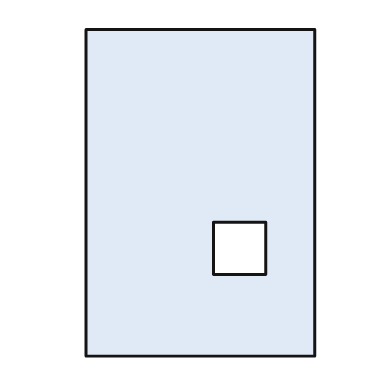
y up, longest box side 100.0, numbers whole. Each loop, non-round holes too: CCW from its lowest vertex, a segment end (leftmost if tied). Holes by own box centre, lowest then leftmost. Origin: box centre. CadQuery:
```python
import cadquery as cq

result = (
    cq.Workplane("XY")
    .moveTo(-35.0, -50.0)
    .lineTo(35.0, -50.0)
    .lineTo(35.0, 50.0)
    .lineTo(-35.0, 50.0)
    .close()
    .moveTo(4.0, -25.0)
    .lineTo(20.0, -25.0)
    .lineTo(20.0, -9.0)
    .lineTo(4.0, -9.0)
    .close()
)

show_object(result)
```